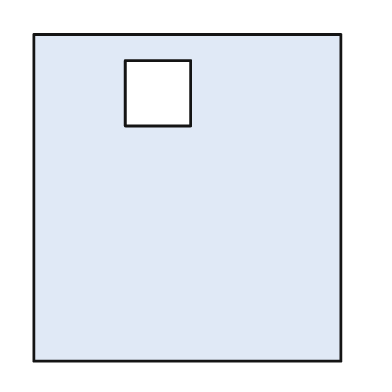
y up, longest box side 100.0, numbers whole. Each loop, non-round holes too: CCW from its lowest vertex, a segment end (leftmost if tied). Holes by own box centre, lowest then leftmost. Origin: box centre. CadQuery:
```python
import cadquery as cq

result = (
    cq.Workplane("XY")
    .moveTo(-47.0, -50.0)
    .lineTo(47.0, -50.0)
    .lineTo(47.0, 50.0)
    .lineTo(-47.0, 50.0)
    .close()
    .moveTo(-19.0, 22.0)
    .lineTo(1.0, 22.0)
    .lineTo(1.0, 42.0)
    .lineTo(-19.0, 42.0)
    .close()
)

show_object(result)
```